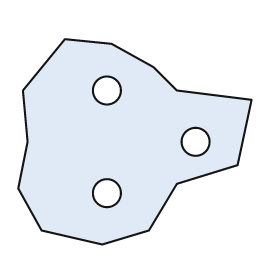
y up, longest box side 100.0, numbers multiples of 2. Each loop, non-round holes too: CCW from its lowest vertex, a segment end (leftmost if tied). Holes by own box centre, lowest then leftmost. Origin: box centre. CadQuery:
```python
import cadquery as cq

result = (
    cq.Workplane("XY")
    .moveTo(-14.0, -44.0)
    .lineTo(6.0, -38.0)
    .lineTo(18.0, -18.0)
    .lineTo(44.0, -10.0)
    .lineTo(50.0, 18.0)
    .lineTo(18.0, 22.0)
    .lineTo(8.0, 32.0)
    .lineTo(-10.0, 42.0)
    .lineTo(-30.0, 44.0)
    .lineTo(-48.0, 22.0)
    .lineTo(-46.0, 0.0)
    .lineTo(-50.0, -20.0)
    .lineTo(-40.0, -38.0)
    .close()
    .moveTo(-12.0, -22.0)
    .circle(6.0)
    .moveTo(26.0, 0.0)
    .circle(6.0)
    .moveTo(-12.0, 22.0)
    .circle(6.0)
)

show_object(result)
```